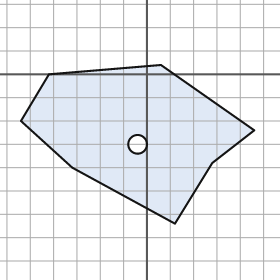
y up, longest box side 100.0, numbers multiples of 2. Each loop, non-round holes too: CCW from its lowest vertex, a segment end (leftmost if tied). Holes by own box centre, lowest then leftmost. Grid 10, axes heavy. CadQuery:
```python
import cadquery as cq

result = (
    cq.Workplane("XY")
    .moveTo(12.0, -64.0)
    .lineTo(28.0, -38.0)
    .lineTo(46.0, -24.0)
    .lineTo(6.0, 4.0)
    .lineTo(-42.0, 0.0)
    .lineTo(-54.0, -20.0)
    .lineTo(-32.0, -40.0)
    .close()
    .moveTo(-4.0, -30.0)
    .circle(4.0)
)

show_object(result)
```